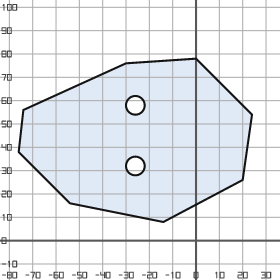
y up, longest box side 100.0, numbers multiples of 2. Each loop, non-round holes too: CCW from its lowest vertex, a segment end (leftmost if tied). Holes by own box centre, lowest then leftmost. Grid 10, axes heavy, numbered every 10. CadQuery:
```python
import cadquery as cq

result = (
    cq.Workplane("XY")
    .moveTo(-14.0, 8.0)
    .lineTo(20.0, 26.0)
    .lineTo(24.0, 54.0)
    .lineTo(0.0, 78.0)
    .lineTo(-30.0, 76.0)
    .lineTo(-74.0, 56.0)
    .lineTo(-76.0, 38.0)
    .lineTo(-54.0, 16.0)
    .close()
    .moveTo(-26.0, 32.0)
    .circle(4.0)
    .moveTo(-26.0, 58.0)
    .circle(4.0)
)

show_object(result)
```